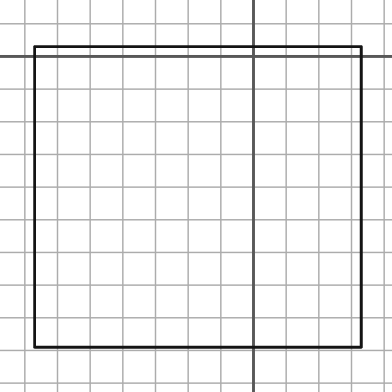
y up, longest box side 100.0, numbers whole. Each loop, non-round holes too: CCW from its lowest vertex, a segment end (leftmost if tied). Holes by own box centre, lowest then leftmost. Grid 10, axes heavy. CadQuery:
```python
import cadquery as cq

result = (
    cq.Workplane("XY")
    .moveTo(-67.0, -89.0)
    .lineTo(33.0, -89.0)
    .lineTo(33.0, 3.0)
    .lineTo(-67.0, 3.0)
    .close()
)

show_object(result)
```